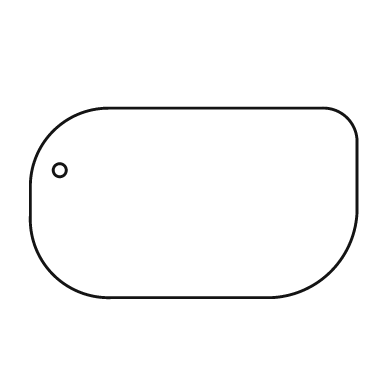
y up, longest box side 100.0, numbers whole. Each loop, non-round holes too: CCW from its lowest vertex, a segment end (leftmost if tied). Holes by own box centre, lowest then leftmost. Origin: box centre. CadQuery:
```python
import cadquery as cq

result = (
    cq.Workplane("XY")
    .moveTo(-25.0, -29.0)
    .lineTo(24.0, -29.0)
    .threePointArc((42.0, -21.0), (50.0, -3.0))
    .lineTo(50.0, 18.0)
    .threePointArc((47.0, 26.0), (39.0, 29.0))
    .lineTo(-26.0, 29.0)
    .threePointArc((-43.0, 22.0), (-50.0, 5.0))
    .lineTo(-50.0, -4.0)
    .threePointArc((-43.0, -22.0), (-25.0, -29.0))
    .close()
    .moveTo(-41.0, 10.0)
    .circle(2.0)
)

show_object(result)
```